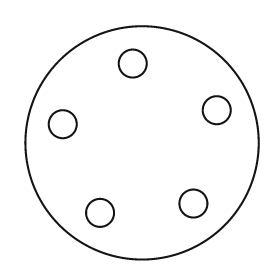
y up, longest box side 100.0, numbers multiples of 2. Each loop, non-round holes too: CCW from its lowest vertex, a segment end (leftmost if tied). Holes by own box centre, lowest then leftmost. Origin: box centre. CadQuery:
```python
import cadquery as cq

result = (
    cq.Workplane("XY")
    .moveTo(0.0, 0.0)
    .circle(50.0)
    .moveTo(-18.0, -30.0)
    .circle(6.0)
    .moveTo(22.0, -26.0)
    .circle(6.0)
    .moveTo(-34.0, 8.0)
    .circle(6.0)
    .moveTo(32.0, 14.0)
    .circle(6.0)
    .moveTo(-4.0, 34.0)
    .circle(6.0)
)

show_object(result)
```